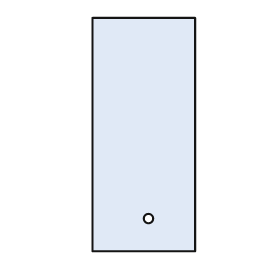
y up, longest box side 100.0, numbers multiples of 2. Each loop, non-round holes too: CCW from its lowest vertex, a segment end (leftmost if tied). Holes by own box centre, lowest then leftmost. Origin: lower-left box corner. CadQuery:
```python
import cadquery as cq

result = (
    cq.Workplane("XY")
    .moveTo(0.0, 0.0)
    .lineTo(44.0, 0.0)
    .lineTo(44.0, 100.0)
    .lineTo(0.0, 100.0)
    .close()
    .moveTo(24.0, 14.0)
    .circle(2.0)
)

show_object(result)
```